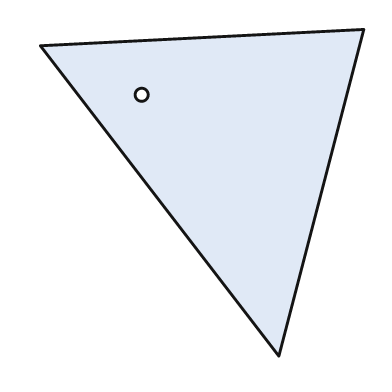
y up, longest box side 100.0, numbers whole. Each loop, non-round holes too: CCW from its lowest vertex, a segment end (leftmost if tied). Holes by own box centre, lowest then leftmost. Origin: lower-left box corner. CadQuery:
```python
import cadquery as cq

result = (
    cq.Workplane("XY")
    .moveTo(73.0, 0.0)
    .lineTo(99.0, 100.0)
    .lineTo(0.0, 95.0)
    .close()
    .moveTo(31.0, 80.0)
    .circle(2.0)
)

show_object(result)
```